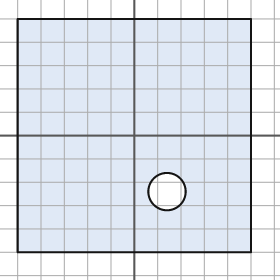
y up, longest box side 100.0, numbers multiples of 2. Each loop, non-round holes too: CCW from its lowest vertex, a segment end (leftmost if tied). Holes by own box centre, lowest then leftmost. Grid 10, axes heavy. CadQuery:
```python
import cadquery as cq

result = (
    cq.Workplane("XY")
    .moveTo(-50.0, -50.0)
    .lineTo(50.0, -50.0)
    .lineTo(50.0, 50.0)
    .lineTo(-50.0, 50.0)
    .close()
    .moveTo(14.0, -24.0)
    .circle(8.0)
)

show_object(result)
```